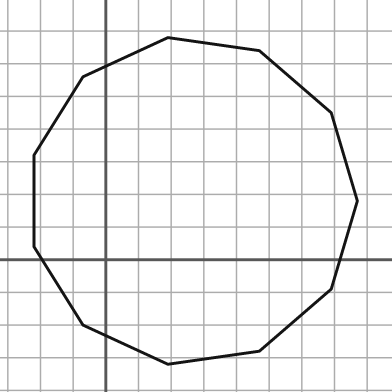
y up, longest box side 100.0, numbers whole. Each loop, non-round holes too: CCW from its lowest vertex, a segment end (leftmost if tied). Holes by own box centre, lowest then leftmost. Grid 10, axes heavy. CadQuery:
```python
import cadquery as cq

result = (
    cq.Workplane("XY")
    .moveTo(19.0, -32.0)
    .lineTo(47.0, -28.0)
    .lineTo(69.0, -9.0)
    .lineTo(77.0, 18.0)
    .lineTo(69.0, 45.0)
    .lineTo(47.0, 64.0)
    .lineTo(19.0, 68.0)
    .lineTo(-7.0, 56.0)
    .lineTo(-22.0, 32.0)
    .lineTo(-22.0, 4.0)
    .lineTo(-7.0, -20.0)
    .close()
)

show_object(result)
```